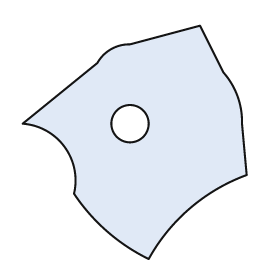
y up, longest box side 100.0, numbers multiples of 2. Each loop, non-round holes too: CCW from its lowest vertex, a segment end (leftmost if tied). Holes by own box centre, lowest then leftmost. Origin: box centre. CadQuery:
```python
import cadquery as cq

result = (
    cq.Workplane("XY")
    .moveTo(6.0, -50.0)
    .threePointArc((24.0, -28.0), (48.0, -14.0))
    .lineTo(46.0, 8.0)
    .threePointArc((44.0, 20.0), (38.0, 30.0))
    .lineTo(28.0, 50.0)
    .lineTo(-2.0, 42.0)
    .threePointArc((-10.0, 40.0), (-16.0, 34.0))
    .lineTo(-48.0, 8.0)
    .threePointArc((-30.0, -2.0), (-26.0, -22.0))
    .threePointArc((-12.0, -38.0), (6.0, -50.0))
    .close()
    .moveTo(-2.0, 8.0)
    .circle(8.0)
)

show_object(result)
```